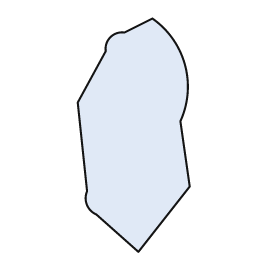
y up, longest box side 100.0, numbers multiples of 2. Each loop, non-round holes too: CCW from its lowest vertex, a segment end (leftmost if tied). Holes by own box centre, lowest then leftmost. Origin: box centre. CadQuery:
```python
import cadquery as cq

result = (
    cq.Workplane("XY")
    .moveTo(2.0, -50.0)
    .lineTo(24.0, -22.0)
    .lineTo(20.0, 6.0)
    .threePointArc((22.0, 30.0), (8.0, 50.0))
    .lineTo(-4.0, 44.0)
    .threePointArc((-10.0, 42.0), (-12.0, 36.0))
    .lineTo(-24.0, 14.0)
    .lineTo(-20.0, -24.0)
    .threePointArc((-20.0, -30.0), (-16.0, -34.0))
    .close()
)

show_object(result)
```